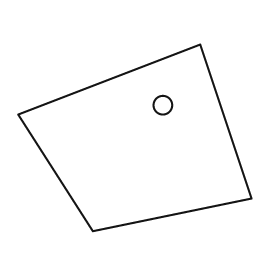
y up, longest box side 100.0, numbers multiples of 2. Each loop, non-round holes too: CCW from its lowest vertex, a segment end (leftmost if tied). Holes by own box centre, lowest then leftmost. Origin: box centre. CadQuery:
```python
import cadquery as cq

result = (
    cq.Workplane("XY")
    .moveTo(-18.0, -40.0)
    .lineTo(50.0, -26.0)
    .lineTo(28.0, 40.0)
    .lineTo(-50.0, 10.0)
    .close()
    .moveTo(12.0, 14.0)
    .circle(4.0)
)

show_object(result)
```